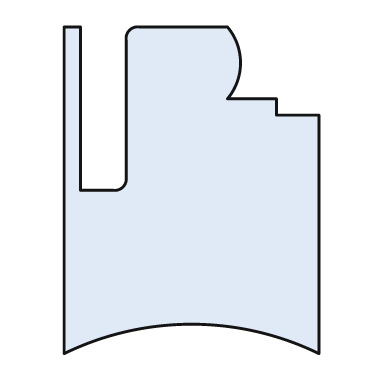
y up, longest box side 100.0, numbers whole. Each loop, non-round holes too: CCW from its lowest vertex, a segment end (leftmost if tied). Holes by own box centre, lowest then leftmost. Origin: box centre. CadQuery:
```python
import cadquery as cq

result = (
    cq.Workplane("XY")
    .moveTo(-39.0, -50.0)
    .threePointArc((0.0, -41.0), (39.0, -50.0))
    .lineTo(39.0, 23.0)
    .lineTo(26.0, 23.0)
    .lineTo(26.0, 28.0)
    .lineTo(11.0, 28.0)
    .threePointArc((15.0, 39.0), (11.0, 50.0))
    .lineTo(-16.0, 50.0)
    .threePointArc((-19.0, 49.0), (-20.0, 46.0))
    .lineTo(-20.0, 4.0)
    .threePointArc((-21.0, 1.0), (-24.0, 0.0))
    .lineTo(-34.0, 0.0)
    .lineTo(-34.0, 50.0)
    .lineTo(-39.0, 50.0)
    .close()
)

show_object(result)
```